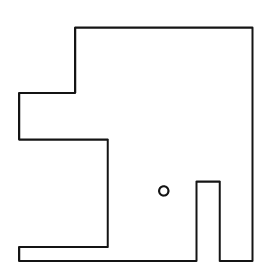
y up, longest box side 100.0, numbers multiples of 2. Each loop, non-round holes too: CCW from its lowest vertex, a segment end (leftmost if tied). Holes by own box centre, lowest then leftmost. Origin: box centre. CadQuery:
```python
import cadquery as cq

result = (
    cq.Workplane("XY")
    .moveTo(-50.0, -50.0)
    .lineTo(26.0, -50.0)
    .lineTo(26.0, -16.0)
    .lineTo(36.0, -16.0)
    .lineTo(36.0, -50.0)
    .lineTo(50.0, -50.0)
    .lineTo(50.0, 50.0)
    .lineTo(-26.0, 50.0)
    .lineTo(-26.0, 22.0)
    .lineTo(-50.0, 22.0)
    .lineTo(-50.0, 2.0)
    .lineTo(-12.0, 2.0)
    .lineTo(-12.0, -44.0)
    .lineTo(-50.0, -44.0)
    .close()
    .moveTo(12.0, -20.0)
    .circle(2.0)
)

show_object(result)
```